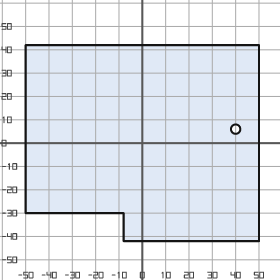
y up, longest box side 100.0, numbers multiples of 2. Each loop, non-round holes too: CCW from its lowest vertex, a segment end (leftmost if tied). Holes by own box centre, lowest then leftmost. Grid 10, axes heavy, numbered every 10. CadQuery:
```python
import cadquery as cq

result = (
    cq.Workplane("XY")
    .moveTo(-8.0, -42.0)
    .lineTo(50.0, -42.0)
    .lineTo(50.0, 42.0)
    .lineTo(-50.0, 42.0)
    .lineTo(-50.0, -30.0)
    .lineTo(-8.0, -30.0)
    .close()
    .moveTo(40.0, 6.0)
    .circle(2.0)
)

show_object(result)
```